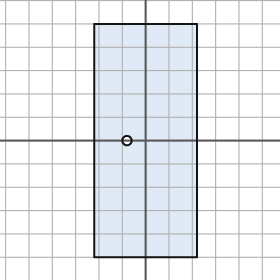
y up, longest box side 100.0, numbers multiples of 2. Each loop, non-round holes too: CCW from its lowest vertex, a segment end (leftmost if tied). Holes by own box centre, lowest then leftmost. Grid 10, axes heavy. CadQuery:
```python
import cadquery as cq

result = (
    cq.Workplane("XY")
    .moveTo(-22.0, -50.0)
    .lineTo(22.0, -50.0)
    .lineTo(22.0, 50.0)
    .lineTo(-22.0, 50.0)
    .close()
    .moveTo(-8.0, 0.0)
    .circle(2.0)
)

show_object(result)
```